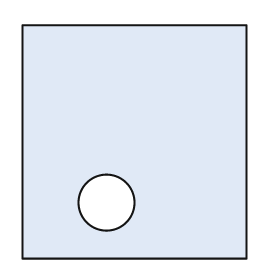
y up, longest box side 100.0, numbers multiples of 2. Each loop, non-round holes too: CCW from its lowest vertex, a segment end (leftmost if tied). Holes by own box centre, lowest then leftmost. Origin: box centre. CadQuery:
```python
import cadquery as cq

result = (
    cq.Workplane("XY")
    .moveTo(-48.0, -50.0)
    .lineTo(48.0, -50.0)
    .lineTo(48.0, 50.0)
    .lineTo(-48.0, 50.0)
    .close()
    .moveTo(-12.0, -26.0)
    .circle(12.0)
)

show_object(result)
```